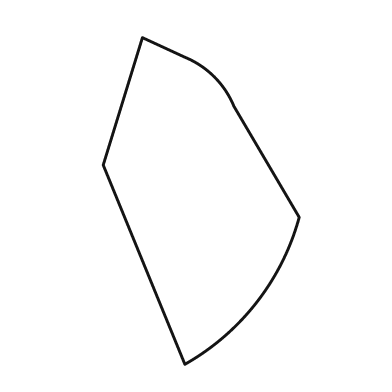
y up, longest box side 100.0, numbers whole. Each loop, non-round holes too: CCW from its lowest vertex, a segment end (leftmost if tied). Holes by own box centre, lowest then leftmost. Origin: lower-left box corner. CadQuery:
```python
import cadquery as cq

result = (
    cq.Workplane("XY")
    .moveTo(25.0, 0.0)
    .threePointArc((47.0, 19.0), (60.0, 45.0))
    .lineTo(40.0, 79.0)
    .threePointArc((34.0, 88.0), (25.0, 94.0))
    .lineTo(12.0, 100.0)
    .lineTo(0.0, 61.0)
    .close()
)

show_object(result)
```